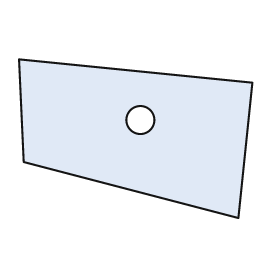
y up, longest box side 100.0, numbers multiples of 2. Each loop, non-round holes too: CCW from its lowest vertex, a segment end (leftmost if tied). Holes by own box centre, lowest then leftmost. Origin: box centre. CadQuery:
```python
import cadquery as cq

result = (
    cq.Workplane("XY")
    .moveTo(44.0, -34.0)
    .lineTo(50.0, 24.0)
    .lineTo(-50.0, 34.0)
    .lineTo(-48.0, -10.0)
    .close()
    .moveTo(2.0, 8.0)
    .circle(6.0)
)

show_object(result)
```